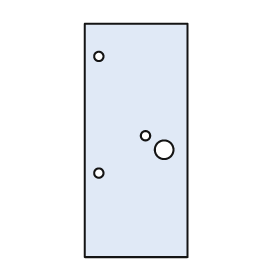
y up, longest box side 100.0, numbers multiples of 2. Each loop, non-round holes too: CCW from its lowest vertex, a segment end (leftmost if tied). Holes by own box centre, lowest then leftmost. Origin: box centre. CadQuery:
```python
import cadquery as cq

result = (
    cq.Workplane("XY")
    .moveTo(-22.0, -50.0)
    .lineTo(22.0, -50.0)
    .lineTo(22.0, 50.0)
    .lineTo(-22.0, 50.0)
    .close()
    .moveTo(-16.0, -14.0)
    .circle(2.0)
    .moveTo(12.0, -4.0)
    .circle(4.0)
    .moveTo(4.0, 2.0)
    .circle(2.0)
    .moveTo(-16.0, 36.0)
    .circle(2.0)
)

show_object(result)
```